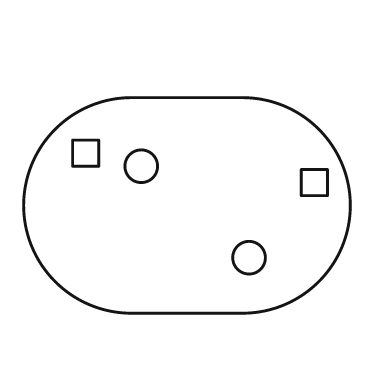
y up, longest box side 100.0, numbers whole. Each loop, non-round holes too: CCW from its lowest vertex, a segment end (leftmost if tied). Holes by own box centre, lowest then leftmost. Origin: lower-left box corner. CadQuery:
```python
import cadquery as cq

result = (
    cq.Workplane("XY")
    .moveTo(33.0, 0.0)
    .lineTo(67.0, 0.0)
    .threePointArc((100.0, 33.0), (67.0, 66.0))
    .lineTo(33.0, 66.0)
    .threePointArc((0.0, 33.0), (33.0, 0.0))
    .close()
    .moveTo(69.0, 17.0)
    .circle(5.0)
    .moveTo(85.0, 36.0)
    .lineTo(93.0, 36.0)
    .lineTo(93.0, 44.0)
    .lineTo(85.0, 44.0)
    .close()
    .moveTo(36.0, 45.0)
    .circle(5.0)
    .moveTo(15.0, 45.0)
    .lineTo(23.0, 45.0)
    .lineTo(23.0, 53.0)
    .lineTo(15.0, 53.0)
    .close()
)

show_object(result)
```